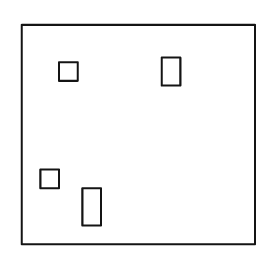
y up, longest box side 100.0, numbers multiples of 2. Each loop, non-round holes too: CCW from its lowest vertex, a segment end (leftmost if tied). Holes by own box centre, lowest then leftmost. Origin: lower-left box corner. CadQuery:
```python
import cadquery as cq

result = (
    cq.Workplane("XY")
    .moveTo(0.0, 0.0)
    .lineTo(100.0, 0.0)
    .lineTo(100.0, 94.0)
    .lineTo(0.0, 94.0)
    .close()
    .moveTo(26.0, 8.0)
    .lineTo(34.0, 8.0)
    .lineTo(34.0, 24.0)
    .lineTo(26.0, 24.0)
    .close()
    .moveTo(8.0, 24.0)
    .lineTo(16.0, 24.0)
    .lineTo(16.0, 32.0)
    .lineTo(8.0, 32.0)
    .close()
    .moveTo(16.0, 70.0)
    .lineTo(24.0, 70.0)
    .lineTo(24.0, 78.0)
    .lineTo(16.0, 78.0)
    .close()
    .moveTo(60.0, 68.0)
    .lineTo(68.0, 68.0)
    .lineTo(68.0, 80.0)
    .lineTo(60.0, 80.0)
    .close()
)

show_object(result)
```